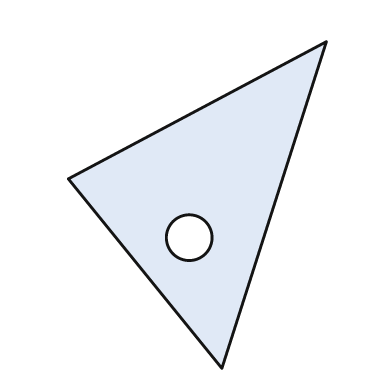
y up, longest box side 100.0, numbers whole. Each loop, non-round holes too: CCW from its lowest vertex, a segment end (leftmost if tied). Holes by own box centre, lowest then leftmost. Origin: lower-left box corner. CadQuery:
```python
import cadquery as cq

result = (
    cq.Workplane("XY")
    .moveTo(47.0, 0.0)
    .lineTo(79.0, 100.0)
    .lineTo(0.0, 58.0)
    .close()
    .moveTo(37.0, 40.0)
    .circle(7.0)
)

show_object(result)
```